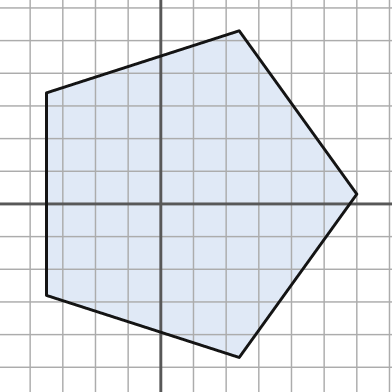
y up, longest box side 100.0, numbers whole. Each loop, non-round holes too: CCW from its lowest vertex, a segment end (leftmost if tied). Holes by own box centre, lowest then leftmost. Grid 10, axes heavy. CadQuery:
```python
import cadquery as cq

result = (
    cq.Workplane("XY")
    .moveTo(24.0, -47.0)
    .lineTo(60.0, 3.0)
    .lineTo(24.0, 53.0)
    .lineTo(-35.0, 34.0)
    .lineTo(-35.0, -28.0)
    .close()
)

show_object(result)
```